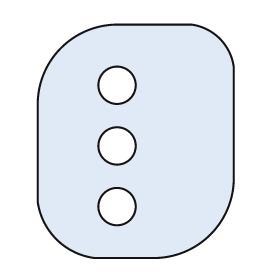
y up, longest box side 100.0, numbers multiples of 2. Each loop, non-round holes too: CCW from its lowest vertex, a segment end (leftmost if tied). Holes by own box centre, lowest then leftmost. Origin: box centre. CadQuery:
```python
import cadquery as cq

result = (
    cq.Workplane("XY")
    .moveTo(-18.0, -50.0)
    .lineTo(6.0, -50.0)
    .threePointArc((32.0, -40.0), (42.0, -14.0))
    .lineTo(42.0, 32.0)
    .threePointArc((36.0, 44.0), (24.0, 50.0))
    .lineTo(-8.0, 50.0)
    .threePointArc((-32.0, 40.0), (-42.0, 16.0))
    .lineTo(-42.0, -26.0)
    .threePointArc((-34.0, -42.0), (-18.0, -50.0))
    .close()
    .moveTo(-8.0, -28.0)
    .circle(8.0)
    .moveTo(-8.0, -2.0)
    .circle(8.0)
    .moveTo(-8.0, 24.0)
    .circle(8.0)
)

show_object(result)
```